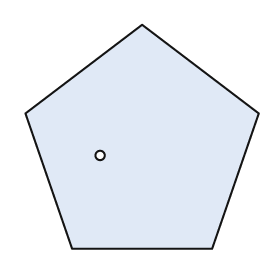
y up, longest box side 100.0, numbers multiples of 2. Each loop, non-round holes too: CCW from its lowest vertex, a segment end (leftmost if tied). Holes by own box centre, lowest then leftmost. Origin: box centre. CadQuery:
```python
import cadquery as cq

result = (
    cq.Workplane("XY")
    .moveTo(-30.0, -48.0)
    .lineTo(30.0, -48.0)
    .lineTo(50.0, 10.0)
    .lineTo(0.0, 48.0)
    .lineTo(-50.0, 10.0)
    .close()
    .moveTo(-18.0, -8.0)
    .circle(2.0)
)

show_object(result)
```